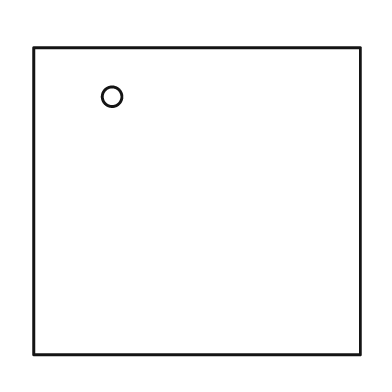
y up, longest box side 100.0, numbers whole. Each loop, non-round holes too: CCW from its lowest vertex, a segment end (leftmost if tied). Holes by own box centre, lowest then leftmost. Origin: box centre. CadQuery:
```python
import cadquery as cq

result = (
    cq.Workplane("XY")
    .moveTo(-50.0, -47.0)
    .lineTo(50.0, -47.0)
    .lineTo(50.0, 47.0)
    .lineTo(-50.0, 47.0)
    .close()
    .moveTo(-26.0, 32.0)
    .circle(3.0)
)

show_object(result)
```